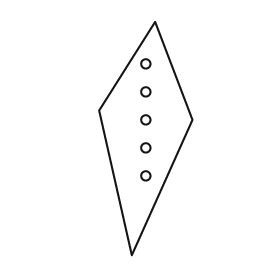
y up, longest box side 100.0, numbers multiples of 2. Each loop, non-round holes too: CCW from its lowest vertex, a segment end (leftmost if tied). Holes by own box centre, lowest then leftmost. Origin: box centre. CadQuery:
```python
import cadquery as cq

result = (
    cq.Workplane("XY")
    .moveTo(-6.0, -50.0)
    .lineTo(20.0, 8.0)
    .lineTo(4.0, 50.0)
    .lineTo(-20.0, 12.0)
    .close()
    .moveTo(0.0, -16.0)
    .circle(2.0)
    .moveTo(0.0, -4.0)
    .circle(2.0)
    .moveTo(0.0, 8.0)
    .circle(2.0)
    .moveTo(0.0, 20.0)
    .circle(2.0)
    .moveTo(0.0, 32.0)
    .circle(2.0)
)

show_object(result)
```